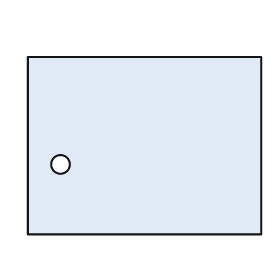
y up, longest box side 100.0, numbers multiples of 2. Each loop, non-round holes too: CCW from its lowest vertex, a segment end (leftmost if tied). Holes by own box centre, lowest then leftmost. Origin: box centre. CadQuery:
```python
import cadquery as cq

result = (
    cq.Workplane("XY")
    .moveTo(-50.0, -38.0)
    .lineTo(50.0, -38.0)
    .lineTo(50.0, 38.0)
    .lineTo(-50.0, 38.0)
    .close()
    .moveTo(-36.0, -8.0)
    .circle(4.0)
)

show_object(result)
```